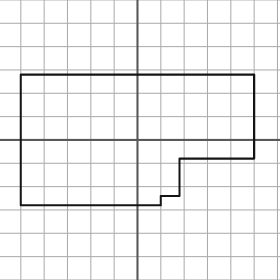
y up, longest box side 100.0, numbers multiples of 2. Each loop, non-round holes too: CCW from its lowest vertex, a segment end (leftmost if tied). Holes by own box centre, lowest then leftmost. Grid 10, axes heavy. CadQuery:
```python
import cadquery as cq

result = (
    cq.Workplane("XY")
    .moveTo(-50.0, -28.0)
    .lineTo(10.0, -28.0)
    .lineTo(10.0, -24.0)
    .lineTo(18.0, -24.0)
    .lineTo(18.0, -8.0)
    .lineTo(50.0, -8.0)
    .lineTo(50.0, 28.0)
    .lineTo(-50.0, 28.0)
    .close()
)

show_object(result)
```